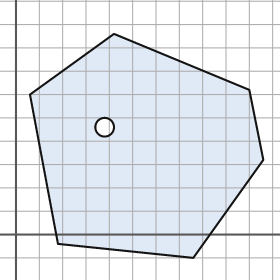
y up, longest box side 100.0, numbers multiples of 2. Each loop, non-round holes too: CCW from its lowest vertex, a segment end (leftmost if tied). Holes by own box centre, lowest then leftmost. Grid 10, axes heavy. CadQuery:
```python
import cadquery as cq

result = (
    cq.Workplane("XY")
    .moveTo(76.0, -10.0)
    .lineTo(106.0, 32.0)
    .lineTo(100.0, 62.0)
    .lineTo(42.0, 86.0)
    .lineTo(6.0, 60.0)
    .lineTo(18.0, -4.0)
    .close()
    .moveTo(38.0, 46.0)
    .circle(4.0)
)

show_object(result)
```